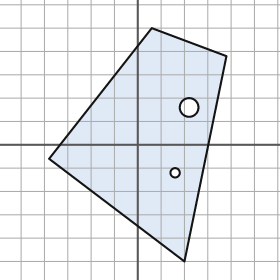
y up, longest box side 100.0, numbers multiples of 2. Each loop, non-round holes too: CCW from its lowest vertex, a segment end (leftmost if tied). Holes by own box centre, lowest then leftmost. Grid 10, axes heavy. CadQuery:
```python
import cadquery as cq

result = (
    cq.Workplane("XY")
    .moveTo(20.0, -50.0)
    .lineTo(38.0, 38.0)
    .lineTo(6.0, 50.0)
    .lineTo(-38.0, -6.0)
    .close()
    .moveTo(16.0, -12.0)
    .circle(2.0)
    .moveTo(22.0, 16.0)
    .circle(4.0)
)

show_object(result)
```